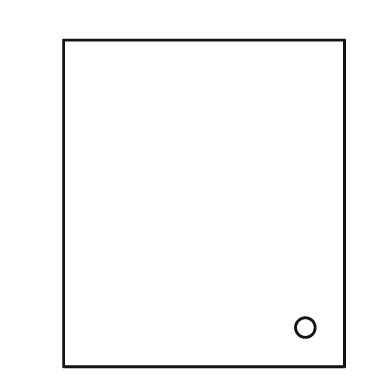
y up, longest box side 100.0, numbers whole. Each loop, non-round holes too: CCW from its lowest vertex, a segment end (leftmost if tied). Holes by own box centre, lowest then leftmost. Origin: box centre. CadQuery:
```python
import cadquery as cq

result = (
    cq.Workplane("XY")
    .moveTo(-43.0, -50.0)
    .lineTo(43.0, -50.0)
    .lineTo(43.0, 50.0)
    .lineTo(-43.0, 50.0)
    .close()
    .moveTo(31.0, -38.0)
    .circle(3.0)
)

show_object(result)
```